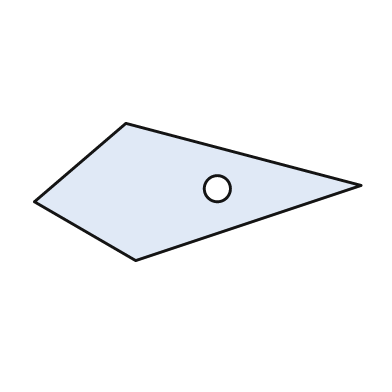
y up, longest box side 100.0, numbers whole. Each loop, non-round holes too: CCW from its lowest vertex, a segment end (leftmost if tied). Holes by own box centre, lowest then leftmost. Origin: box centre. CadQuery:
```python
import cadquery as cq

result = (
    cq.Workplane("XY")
    .moveTo(-19.0, -21.0)
    .lineTo(50.0, 2.0)
    .lineTo(-22.0, 21.0)
    .lineTo(-50.0, -3.0)
    .close()
    .moveTo(6.0, 1.0)
    .circle(4.0)
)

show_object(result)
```